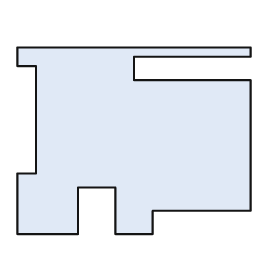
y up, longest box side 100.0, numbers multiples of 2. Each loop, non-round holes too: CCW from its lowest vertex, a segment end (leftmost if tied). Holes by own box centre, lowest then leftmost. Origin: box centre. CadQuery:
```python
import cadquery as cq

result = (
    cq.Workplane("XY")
    .moveTo(-50.0, -40.0)
    .lineTo(-24.0, -40.0)
    .lineTo(-24.0, -20.0)
    .lineTo(-8.0, -20.0)
    .lineTo(-8.0, -40.0)
    .lineTo(8.0, -40.0)
    .lineTo(8.0, -30.0)
    .lineTo(50.0, -30.0)
    .lineTo(50.0, 26.0)
    .lineTo(0.0, 26.0)
    .lineTo(0.0, 36.0)
    .lineTo(50.0, 36.0)
    .lineTo(50.0, 40.0)
    .lineTo(-50.0, 40.0)
    .lineTo(-50.0, 32.0)
    .lineTo(-42.0, 32.0)
    .lineTo(-42.0, -14.0)
    .lineTo(-50.0, -14.0)
    .close()
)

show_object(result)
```